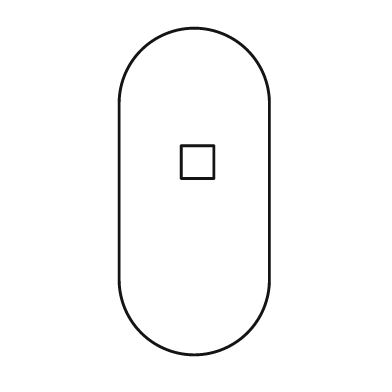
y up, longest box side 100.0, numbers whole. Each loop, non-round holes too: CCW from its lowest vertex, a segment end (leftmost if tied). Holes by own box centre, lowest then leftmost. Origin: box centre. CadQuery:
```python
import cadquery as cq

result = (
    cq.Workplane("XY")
    .moveTo(-23.0, -27.0)
    .threePointArc((0.0, -50.0), (23.0, -27.0))
    .lineTo(23.0, 27.0)
    .threePointArc((0.0, 50.0), (-23.0, 27.0))
    .close()
    .moveTo(-4.0, 4.0)
    .lineTo(6.0, 4.0)
    .lineTo(6.0, 14.0)
    .lineTo(-4.0, 14.0)
    .close()
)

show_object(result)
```